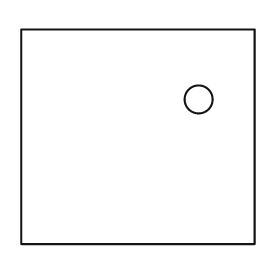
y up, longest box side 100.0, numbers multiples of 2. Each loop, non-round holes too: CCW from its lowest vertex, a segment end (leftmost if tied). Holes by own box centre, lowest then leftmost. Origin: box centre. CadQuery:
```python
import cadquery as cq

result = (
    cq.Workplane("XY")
    .moveTo(-50.0, -46.0)
    .lineTo(50.0, -46.0)
    .lineTo(50.0, 46.0)
    .lineTo(-50.0, 46.0)
    .close()
    .moveTo(26.0, 16.0)
    .circle(6.0)
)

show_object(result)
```